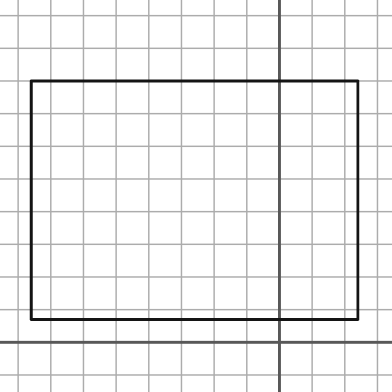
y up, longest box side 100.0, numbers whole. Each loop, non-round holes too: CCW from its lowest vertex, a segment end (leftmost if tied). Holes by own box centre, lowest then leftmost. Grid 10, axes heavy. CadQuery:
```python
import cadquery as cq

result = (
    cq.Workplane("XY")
    .moveTo(-76.0, 7.0)
    .lineTo(24.0, 7.0)
    .lineTo(24.0, 80.0)
    .lineTo(-76.0, 80.0)
    .close()
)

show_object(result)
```